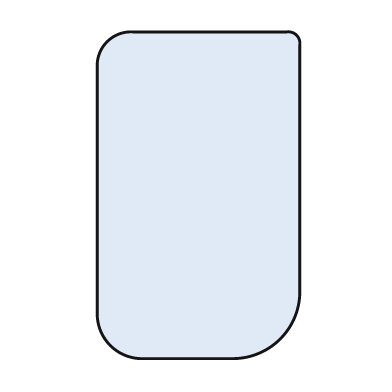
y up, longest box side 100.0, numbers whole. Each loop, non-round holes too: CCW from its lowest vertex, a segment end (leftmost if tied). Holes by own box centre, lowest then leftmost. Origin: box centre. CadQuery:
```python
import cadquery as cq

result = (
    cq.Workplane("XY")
    .moveTo(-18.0, -50.0)
    .lineTo(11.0, -50.0)
    .threePointArc((25.0, -44.0), (31.0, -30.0))
    .lineTo(31.0, 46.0)
    .threePointArc((30.0, 49.0), (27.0, 50.0))
    .lineTo(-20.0, 50.0)
    .threePointArc((-28.0, 47.0), (-31.0, 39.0))
    .lineTo(-31.0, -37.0)
    .threePointArc((-27.0, -46.0), (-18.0, -50.0))
    .close()
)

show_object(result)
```